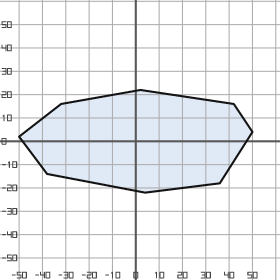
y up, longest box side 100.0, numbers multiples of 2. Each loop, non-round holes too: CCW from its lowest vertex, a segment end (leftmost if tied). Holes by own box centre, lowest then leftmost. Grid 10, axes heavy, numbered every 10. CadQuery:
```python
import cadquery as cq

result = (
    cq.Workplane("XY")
    .moveTo(4.0, -22.0)
    .lineTo(36.0, -18.0)
    .lineTo(50.0, 4.0)
    .lineTo(42.0, 16.0)
    .lineTo(2.0, 22.0)
    .lineTo(-32.0, 16.0)
    .lineTo(-50.0, 2.0)
    .lineTo(-38.0, -14.0)
    .close()
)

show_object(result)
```